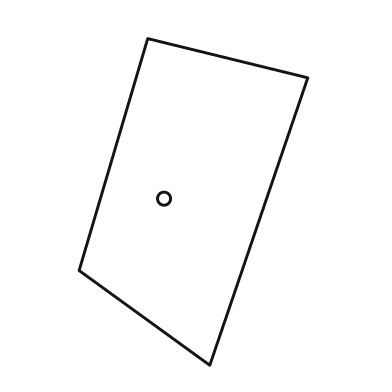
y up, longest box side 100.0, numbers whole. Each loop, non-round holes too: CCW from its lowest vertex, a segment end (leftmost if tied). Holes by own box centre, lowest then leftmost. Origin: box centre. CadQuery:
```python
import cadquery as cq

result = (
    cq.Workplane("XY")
    .moveTo(5.0, -50.0)
    .lineTo(35.0, 38.0)
    .lineTo(-14.0, 50.0)
    .lineTo(-35.0, -21.0)
    .close()
    .moveTo(-9.0, 1.0)
    .circle(2.0)
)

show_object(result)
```